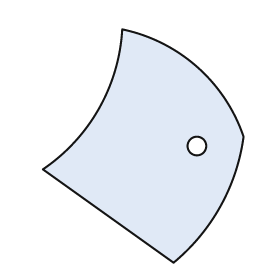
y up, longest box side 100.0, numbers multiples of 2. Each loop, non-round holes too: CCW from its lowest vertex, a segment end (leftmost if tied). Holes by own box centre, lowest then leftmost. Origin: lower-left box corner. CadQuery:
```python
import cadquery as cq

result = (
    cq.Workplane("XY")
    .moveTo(56.0, 0.0)
    .threePointArc((76.0, 24.0), (86.0, 54.0))
    .threePointArc((66.0, 84.0), (34.0, 100.0))
    .threePointArc((24.0, 66.0), (0.0, 40.0))
    .close()
    .moveTo(66.0, 50.0)
    .circle(4.0)
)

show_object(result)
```